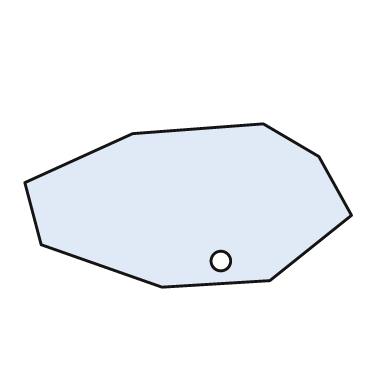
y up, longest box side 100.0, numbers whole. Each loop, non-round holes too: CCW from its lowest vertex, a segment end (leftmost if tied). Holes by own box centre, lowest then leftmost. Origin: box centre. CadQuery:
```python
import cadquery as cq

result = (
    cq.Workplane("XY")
    .moveTo(-8.0, -25.0)
    .lineTo(25.0, -23.0)
    .lineTo(50.0, -3.0)
    .lineTo(40.0, 15.0)
    .lineTo(23.0, 25.0)
    .lineTo(-17.0, 22.0)
    .lineTo(-50.0, 7.0)
    .lineTo(-45.0, -12.0)
    .close()
    .moveTo(10.0, -17.0)
    .circle(3.0)
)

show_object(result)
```